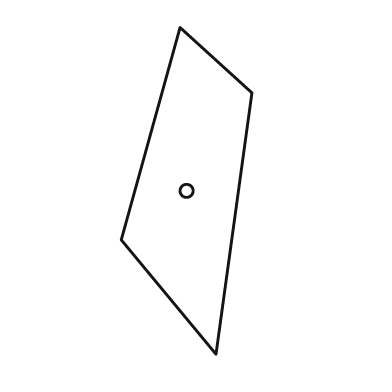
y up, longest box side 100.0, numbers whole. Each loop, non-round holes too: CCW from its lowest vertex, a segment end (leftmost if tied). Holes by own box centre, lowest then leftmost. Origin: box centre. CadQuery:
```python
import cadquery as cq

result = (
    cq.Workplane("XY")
    .moveTo(9.0, -50.0)
    .lineTo(20.0, 30.0)
    .lineTo(-2.0, 50.0)
    .lineTo(-20.0, -15.0)
    .close()
    .moveTo(0.0, 0.0)
    .circle(2.0)
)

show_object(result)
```